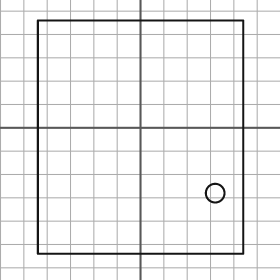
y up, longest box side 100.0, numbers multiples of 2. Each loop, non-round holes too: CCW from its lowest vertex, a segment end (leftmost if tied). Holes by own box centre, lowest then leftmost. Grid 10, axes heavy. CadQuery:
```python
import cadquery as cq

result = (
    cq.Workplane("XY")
    .moveTo(-44.0, -54.0)
    .lineTo(44.0, -54.0)
    .lineTo(44.0, 46.0)
    .lineTo(-44.0, 46.0)
    .close()
    .moveTo(32.0, -28.0)
    .circle(4.0)
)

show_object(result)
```